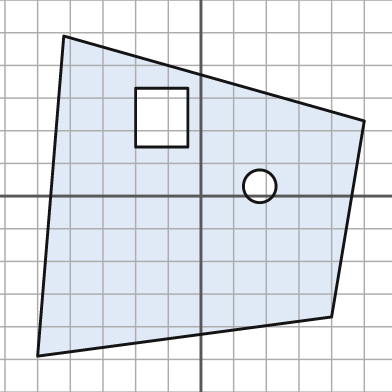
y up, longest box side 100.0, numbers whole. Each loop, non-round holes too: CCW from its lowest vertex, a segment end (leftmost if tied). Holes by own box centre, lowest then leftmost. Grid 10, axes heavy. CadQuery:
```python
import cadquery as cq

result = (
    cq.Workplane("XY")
    .moveTo(-50.0, -49.0)
    .lineTo(40.0, -37.0)
    .lineTo(50.0, 23.0)
    .lineTo(-42.0, 49.0)
    .close()
    .moveTo(18.0, 3.0)
    .circle(5.0)
    .moveTo(-20.0, 15.0)
    .lineTo(-4.0, 15.0)
    .lineTo(-4.0, 33.0)
    .lineTo(-20.0, 33.0)
    .close()
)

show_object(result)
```